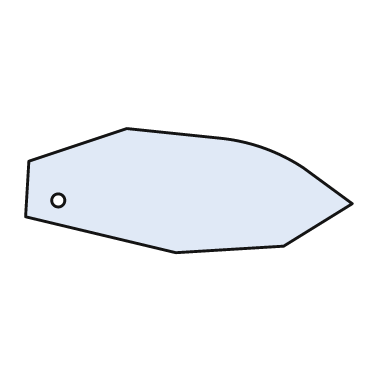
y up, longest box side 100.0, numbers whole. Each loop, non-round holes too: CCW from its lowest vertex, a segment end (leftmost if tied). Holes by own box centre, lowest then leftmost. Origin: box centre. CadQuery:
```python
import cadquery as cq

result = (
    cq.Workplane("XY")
    .moveTo(-4.0, -19.0)
    .lineTo(29.0, -17.0)
    .lineTo(50.0, -4.0)
    .lineTo(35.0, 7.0)
    .threePointArc((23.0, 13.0), (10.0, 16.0))
    .lineTo(-19.0, 19.0)
    .lineTo(-49.0, 9.0)
    .lineTo(-50.0, -8.0)
    .close()
    .moveTo(-40.0, -3.0)
    .circle(2.0)
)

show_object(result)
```